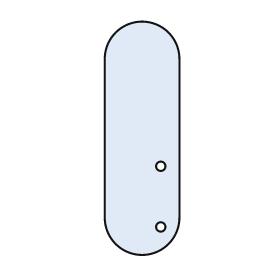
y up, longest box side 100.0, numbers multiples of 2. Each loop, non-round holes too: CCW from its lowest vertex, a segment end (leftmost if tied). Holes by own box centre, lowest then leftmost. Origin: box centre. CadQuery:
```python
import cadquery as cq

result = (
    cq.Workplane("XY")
    .moveTo(-16.0, -34.0)
    .threePointArc((0.0, -50.0), (16.0, -34.0))
    .lineTo(16.0, 34.0)
    .threePointArc((0.0, 50.0), (-16.0, 34.0))
    .close()
    .moveTo(8.0, -38.0)
    .circle(2.0)
    .moveTo(8.0, -12.0)
    .circle(2.0)
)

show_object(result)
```